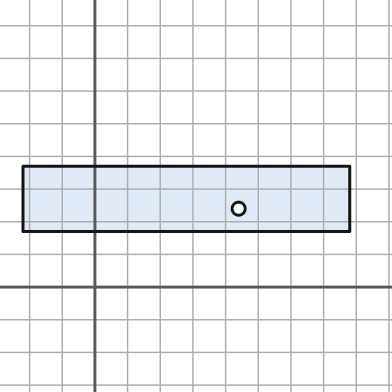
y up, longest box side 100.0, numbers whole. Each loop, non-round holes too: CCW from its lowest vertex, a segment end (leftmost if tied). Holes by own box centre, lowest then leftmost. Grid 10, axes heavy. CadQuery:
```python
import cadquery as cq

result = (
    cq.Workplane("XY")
    .moveTo(-22.0, 17.0)
    .lineTo(78.0, 17.0)
    .lineTo(78.0, 37.0)
    .lineTo(-22.0, 37.0)
    .close()
    .moveTo(44.0, 24.0)
    .circle(2.0)
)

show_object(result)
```